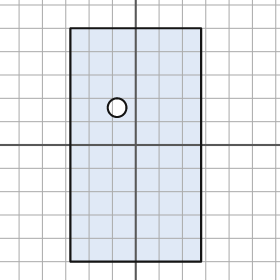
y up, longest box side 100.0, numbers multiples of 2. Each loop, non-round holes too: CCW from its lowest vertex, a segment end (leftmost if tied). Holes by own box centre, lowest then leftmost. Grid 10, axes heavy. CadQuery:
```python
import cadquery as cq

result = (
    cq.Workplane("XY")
    .moveTo(-28.0, -50.0)
    .lineTo(28.0, -50.0)
    .lineTo(28.0, 50.0)
    .lineTo(-28.0, 50.0)
    .close()
    .moveTo(-8.0, 16.0)
    .circle(4.0)
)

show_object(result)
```